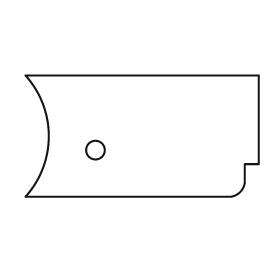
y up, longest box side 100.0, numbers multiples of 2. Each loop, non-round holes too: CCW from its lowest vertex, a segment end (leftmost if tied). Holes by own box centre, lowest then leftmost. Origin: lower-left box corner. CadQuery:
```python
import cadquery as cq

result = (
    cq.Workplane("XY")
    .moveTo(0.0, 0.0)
    .lineTo(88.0, 0.0)
    .threePointArc((92.0, 2.0), (94.0, 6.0))
    .lineTo(94.0, 14.0)
    .lineTo(100.0, 14.0)
    .lineTo(100.0, 52.0)
    .lineTo(0.0, 52.0)
    .threePointArc((10.0, 26.0), (0.0, 0.0))
    .close()
    .moveTo(30.0, 20.0)
    .circle(4.0)
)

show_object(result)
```